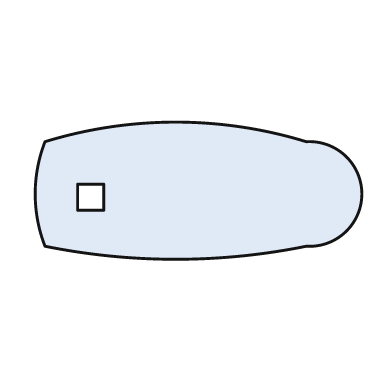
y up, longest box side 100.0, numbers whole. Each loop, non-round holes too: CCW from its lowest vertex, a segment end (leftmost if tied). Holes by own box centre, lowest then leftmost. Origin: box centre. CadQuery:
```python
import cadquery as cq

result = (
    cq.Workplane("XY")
    .moveTo(-47.0, -17.0)
    .threePointArc((-7.0, -21.0), (33.0, -17.0))
    .threePointArc((50.0, -1.0), (33.0, 15.0))
    .threePointArc((-7.0, 21.0), (-47.0, 15.0))
    .threePointArc((-50.0, -1.0), (-47.0, -17.0))
    .close()
    .moveTo(-37.0, -6.0)
    .lineTo(-29.0, -6.0)
    .lineTo(-29.0, 2.0)
    .lineTo(-37.0, 2.0)
    .close()
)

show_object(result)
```